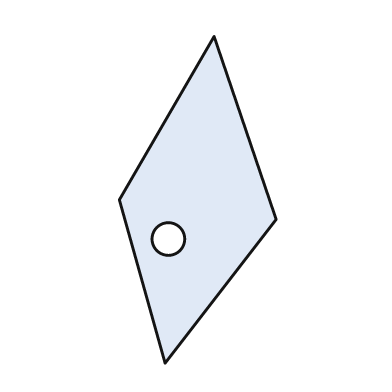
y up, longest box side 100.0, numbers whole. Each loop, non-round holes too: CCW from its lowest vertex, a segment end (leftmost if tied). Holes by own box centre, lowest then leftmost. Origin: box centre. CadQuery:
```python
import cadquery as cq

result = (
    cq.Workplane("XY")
    .moveTo(-10.0, -50.0)
    .lineTo(24.0, -6.0)
    .lineTo(5.0, 50.0)
    .lineTo(-24.0, 0.0)
    .close()
    .moveTo(-9.0, -12.0)
    .circle(5.0)
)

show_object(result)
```